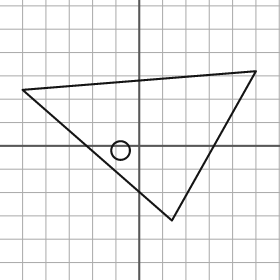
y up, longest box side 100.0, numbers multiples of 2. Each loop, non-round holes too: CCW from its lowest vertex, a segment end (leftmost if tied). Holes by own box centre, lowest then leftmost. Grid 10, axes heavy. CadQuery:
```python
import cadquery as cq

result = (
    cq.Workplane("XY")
    .moveTo(14.0, -32.0)
    .lineTo(50.0, 32.0)
    .lineTo(-50.0, 24.0)
    .close()
    .moveTo(-8.0, -2.0)
    .circle(4.0)
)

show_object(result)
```